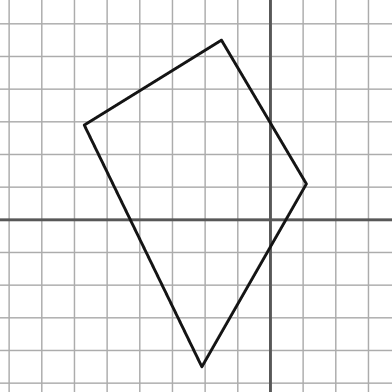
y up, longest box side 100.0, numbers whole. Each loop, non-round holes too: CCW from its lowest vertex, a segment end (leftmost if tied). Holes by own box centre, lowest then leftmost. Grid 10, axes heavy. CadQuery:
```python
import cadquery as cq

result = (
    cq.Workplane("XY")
    .moveTo(-21.0, -45.0)
    .lineTo(11.0, 11.0)
    .lineTo(-15.0, 55.0)
    .lineTo(-57.0, 29.0)
    .close()
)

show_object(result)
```